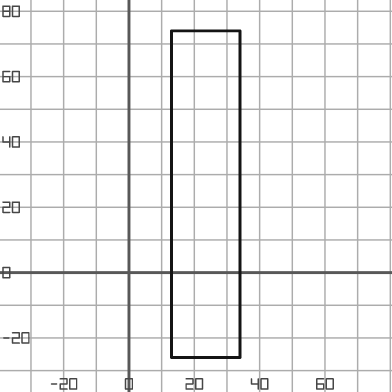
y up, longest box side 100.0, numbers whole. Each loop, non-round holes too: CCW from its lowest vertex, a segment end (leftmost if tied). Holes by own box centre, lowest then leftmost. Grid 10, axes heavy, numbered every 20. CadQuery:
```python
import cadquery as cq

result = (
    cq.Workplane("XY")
    .moveTo(13.0, -26.0)
    .lineTo(34.0, -26.0)
    .lineTo(34.0, 74.0)
    .lineTo(13.0, 74.0)
    .close()
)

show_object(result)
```